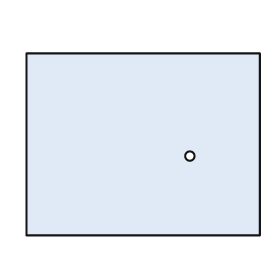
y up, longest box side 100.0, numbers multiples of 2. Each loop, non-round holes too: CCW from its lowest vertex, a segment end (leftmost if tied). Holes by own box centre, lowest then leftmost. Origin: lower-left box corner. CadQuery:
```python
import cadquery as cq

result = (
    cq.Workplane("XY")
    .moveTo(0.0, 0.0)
    .lineTo(100.0, 0.0)
    .lineTo(100.0, 78.0)
    .lineTo(0.0, 78.0)
    .close()
    .moveTo(70.0, 34.0)
    .circle(2.0)
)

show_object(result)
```